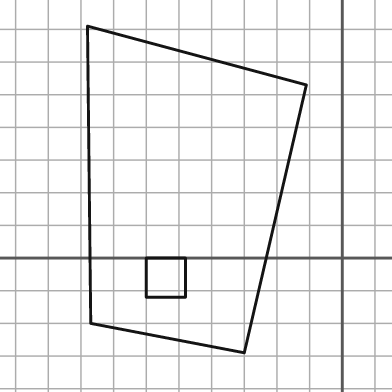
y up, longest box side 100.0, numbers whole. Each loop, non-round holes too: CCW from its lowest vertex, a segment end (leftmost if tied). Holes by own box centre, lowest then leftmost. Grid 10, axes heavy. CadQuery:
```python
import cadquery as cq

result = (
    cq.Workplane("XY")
    .moveTo(-30.0, -29.0)
    .lineTo(-11.0, 53.0)
    .lineTo(-78.0, 71.0)
    .lineTo(-77.0, -20.0)
    .close()
    .moveTo(-60.0, -12.0)
    .lineTo(-48.0, -12.0)
    .lineTo(-48.0, 0.0)
    .lineTo(-60.0, 0.0)
    .close()
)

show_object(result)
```